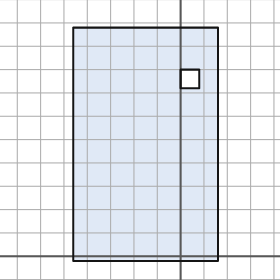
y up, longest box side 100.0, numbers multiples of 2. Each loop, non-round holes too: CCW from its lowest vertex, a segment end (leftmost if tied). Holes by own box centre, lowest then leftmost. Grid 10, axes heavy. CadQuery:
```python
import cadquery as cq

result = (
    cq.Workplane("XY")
    .moveTo(-46.0, -2.0)
    .lineTo(16.0, -2.0)
    .lineTo(16.0, 98.0)
    .lineTo(-46.0, 98.0)
    .close()
    .moveTo(0.0, 72.0)
    .lineTo(8.0, 72.0)
    .lineTo(8.0, 80.0)
    .lineTo(0.0, 80.0)
    .close()
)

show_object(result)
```